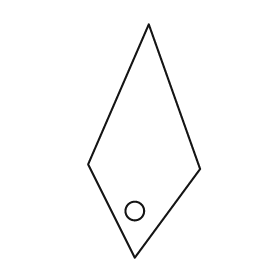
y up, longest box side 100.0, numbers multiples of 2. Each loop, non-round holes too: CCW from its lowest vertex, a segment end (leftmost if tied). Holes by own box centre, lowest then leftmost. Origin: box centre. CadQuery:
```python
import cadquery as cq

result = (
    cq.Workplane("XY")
    .moveTo(-4.0, -50.0)
    .lineTo(24.0, -12.0)
    .lineTo(2.0, 50.0)
    .lineTo(-24.0, -10.0)
    .close()
    .moveTo(-4.0, -30.0)
    .circle(4.0)
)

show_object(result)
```